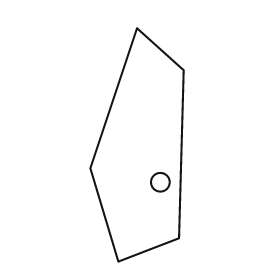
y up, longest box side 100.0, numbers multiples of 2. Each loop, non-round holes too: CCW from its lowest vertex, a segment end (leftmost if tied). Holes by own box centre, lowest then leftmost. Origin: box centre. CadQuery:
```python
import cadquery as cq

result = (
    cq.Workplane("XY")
    .moveTo(-8.0, -50.0)
    .lineTo(18.0, -40.0)
    .lineTo(20.0, 32.0)
    .lineTo(0.0, 50.0)
    .lineTo(-20.0, -10.0)
    .close()
    .moveTo(10.0, -16.0)
    .circle(4.0)
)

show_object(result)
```